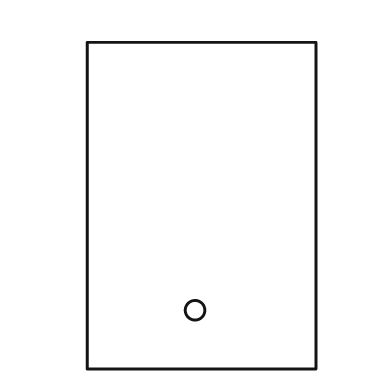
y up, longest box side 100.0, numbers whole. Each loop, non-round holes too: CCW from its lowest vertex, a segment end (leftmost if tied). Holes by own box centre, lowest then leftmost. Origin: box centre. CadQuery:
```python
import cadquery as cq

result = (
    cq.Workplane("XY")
    .moveTo(-35.0, -50.0)
    .lineTo(35.0, -50.0)
    .lineTo(35.0, 50.0)
    .lineTo(-35.0, 50.0)
    .close()
    .moveTo(-2.0, -32.0)
    .circle(3.0)
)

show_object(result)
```